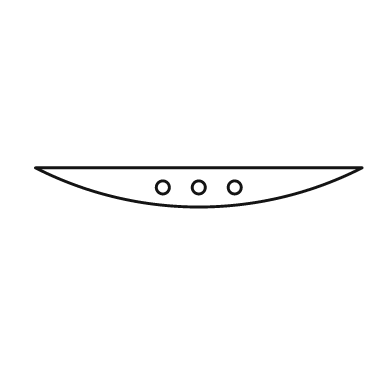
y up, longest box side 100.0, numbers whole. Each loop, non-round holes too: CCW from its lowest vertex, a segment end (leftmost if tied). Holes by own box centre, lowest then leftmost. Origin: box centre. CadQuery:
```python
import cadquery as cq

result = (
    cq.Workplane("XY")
    .moveTo(-50.0, 6.0)
    .threePointArc((0.0, -6.0), (50.0, 6.0))
    .close()
    .moveTo(-11.0, 0.0)
    .circle(2.0)
    .moveTo(0.0, 0.0)
    .circle(2.0)
    .moveTo(11.0, 0.0)
    .circle(2.0)
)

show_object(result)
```